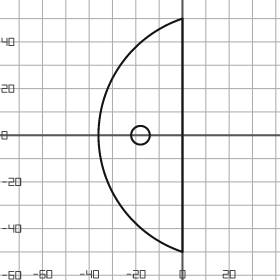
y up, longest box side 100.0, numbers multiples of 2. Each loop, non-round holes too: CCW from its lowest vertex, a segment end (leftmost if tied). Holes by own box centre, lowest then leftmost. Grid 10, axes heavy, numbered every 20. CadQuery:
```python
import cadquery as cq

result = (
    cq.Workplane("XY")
    .moveTo(0.0, -50.0)
    .lineTo(0.0, 50.0)
    .threePointArc((-36.0, 0.0), (0.0, -50.0))
    .close()
    .moveTo(-18.0, 0.0)
    .circle(4.0)
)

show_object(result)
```